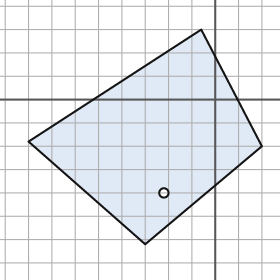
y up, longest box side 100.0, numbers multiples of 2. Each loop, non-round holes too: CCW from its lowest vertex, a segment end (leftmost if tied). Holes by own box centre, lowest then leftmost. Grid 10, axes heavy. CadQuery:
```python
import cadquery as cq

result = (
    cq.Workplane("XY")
    .moveTo(-30.0, -62.0)
    .lineTo(20.0, -20.0)
    .lineTo(-6.0, 30.0)
    .lineTo(-80.0, -18.0)
    .close()
    .moveTo(-22.0, -40.0)
    .circle(2.0)
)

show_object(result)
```